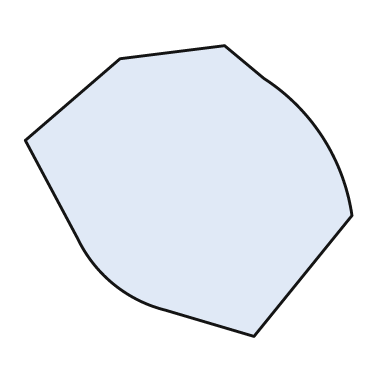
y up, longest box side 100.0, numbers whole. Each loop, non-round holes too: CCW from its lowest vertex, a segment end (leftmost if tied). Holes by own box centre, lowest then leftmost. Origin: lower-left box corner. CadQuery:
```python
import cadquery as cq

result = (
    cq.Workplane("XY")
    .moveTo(70.0, 0.0)
    .lineTo(100.0, 37.0)
    .threePointArc((91.0, 61.0), (73.0, 79.0))
    .lineTo(61.0, 89.0)
    .lineTo(29.0, 85.0)
    .lineTo(0.0, 60.0)
    .lineTo(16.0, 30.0)
    .threePointArc((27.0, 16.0), (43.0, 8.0))
    .close()
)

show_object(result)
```